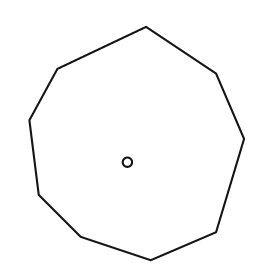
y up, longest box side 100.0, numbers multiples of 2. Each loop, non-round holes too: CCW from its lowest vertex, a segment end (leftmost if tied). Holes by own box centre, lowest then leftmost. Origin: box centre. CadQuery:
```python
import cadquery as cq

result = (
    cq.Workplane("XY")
    .moveTo(6.0, -50.0)
    .lineTo(34.0, -38.0)
    .lineTo(46.0, 2.0)
    .lineTo(34.0, 30.0)
    .lineTo(4.0, 50.0)
    .lineTo(-34.0, 32.0)
    .lineTo(-46.0, 10.0)
    .lineTo(-42.0, -22.0)
    .lineTo(-24.0, -40.0)
    .close()
    .moveTo(-4.0, -8.0)
    .circle(2.0)
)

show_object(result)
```